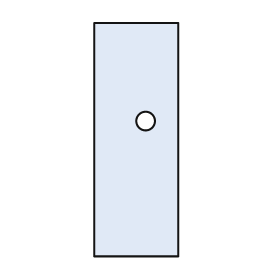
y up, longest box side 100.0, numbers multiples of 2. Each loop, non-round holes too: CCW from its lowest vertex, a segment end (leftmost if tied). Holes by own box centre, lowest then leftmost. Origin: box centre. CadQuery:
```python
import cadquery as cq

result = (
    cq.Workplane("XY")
    .moveTo(-18.0, -50.0)
    .lineTo(18.0, -50.0)
    .lineTo(18.0, 50.0)
    .lineTo(-18.0, 50.0)
    .close()
    .moveTo(4.0, 8.0)
    .circle(4.0)
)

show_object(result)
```